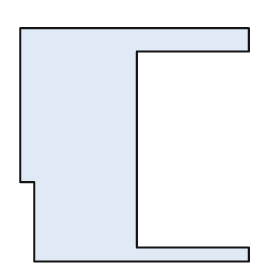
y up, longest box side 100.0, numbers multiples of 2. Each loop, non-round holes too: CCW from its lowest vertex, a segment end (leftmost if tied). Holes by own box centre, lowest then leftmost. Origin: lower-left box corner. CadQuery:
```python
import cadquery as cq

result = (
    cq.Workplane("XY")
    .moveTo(6.0, 0.0)
    .lineTo(98.0, 0.0)
    .lineTo(98.0, 6.0)
    .lineTo(50.0, 6.0)
    .lineTo(50.0, 90.0)
    .lineTo(98.0, 90.0)
    .lineTo(98.0, 100.0)
    .lineTo(0.0, 100.0)
    .lineTo(0.0, 34.0)
    .lineTo(6.0, 34.0)
    .close()
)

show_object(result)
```